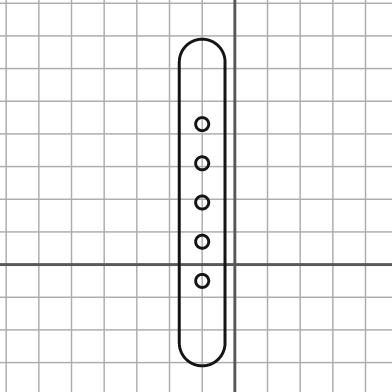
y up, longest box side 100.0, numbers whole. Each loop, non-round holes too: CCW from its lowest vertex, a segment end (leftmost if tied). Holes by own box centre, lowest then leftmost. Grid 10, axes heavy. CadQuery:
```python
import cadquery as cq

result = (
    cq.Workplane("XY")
    .moveTo(-17.0, -24.0)
    .threePointArc((-10.0, -31.0), (-3.0, -24.0))
    .lineTo(-3.0, 62.0)
    .threePointArc((-10.0, 69.0), (-17.0, 62.0))
    .close()
    .moveTo(-10.0, -5.0)
    .circle(2.0)
    .moveTo(-10.0, 7.0)
    .circle(2.0)
    .moveTo(-10.0, 19.0)
    .circle(2.0)
    .moveTo(-10.0, 31.0)
    .circle(2.0)
    .moveTo(-10.0, 43.0)
    .circle(2.0)
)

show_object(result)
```